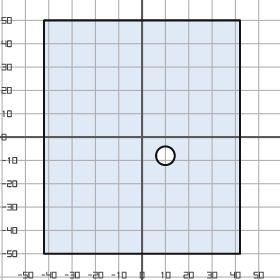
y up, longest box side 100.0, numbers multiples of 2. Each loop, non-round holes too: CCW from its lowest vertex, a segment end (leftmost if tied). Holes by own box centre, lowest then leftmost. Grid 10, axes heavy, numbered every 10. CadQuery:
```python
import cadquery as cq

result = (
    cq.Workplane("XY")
    .moveTo(-42.0, -50.0)
    .lineTo(42.0, -50.0)
    .lineTo(42.0, 50.0)
    .lineTo(-42.0, 50.0)
    .close()
    .moveTo(10.0, -8.0)
    .circle(4.0)
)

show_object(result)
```